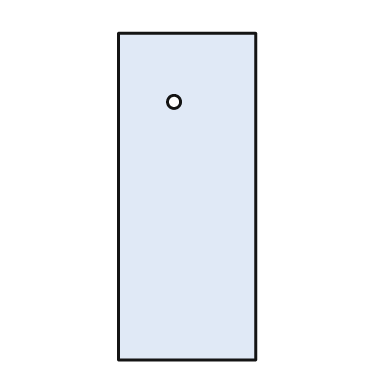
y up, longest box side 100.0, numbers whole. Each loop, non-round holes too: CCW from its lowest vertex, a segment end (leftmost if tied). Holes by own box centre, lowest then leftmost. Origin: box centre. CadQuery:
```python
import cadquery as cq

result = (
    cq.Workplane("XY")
    .moveTo(-21.0, -50.0)
    .lineTo(21.0, -50.0)
    .lineTo(21.0, 50.0)
    .lineTo(-21.0, 50.0)
    .close()
    .moveTo(-4.0, 29.0)
    .circle(2.0)
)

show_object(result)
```